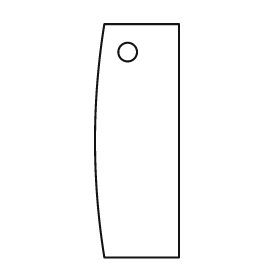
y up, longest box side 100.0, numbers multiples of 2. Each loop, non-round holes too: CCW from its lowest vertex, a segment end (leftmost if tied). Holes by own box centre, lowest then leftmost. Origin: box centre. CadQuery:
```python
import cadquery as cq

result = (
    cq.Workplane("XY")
    .moveTo(-14.0, -50.0)
    .lineTo(18.0, -50.0)
    .lineTo(18.0, 50.0)
    .lineTo(-14.0, 50.0)
    .threePointArc((-18.0, 0.0), (-14.0, -50.0))
    .close()
    .moveTo(-4.0, 38.0)
    .circle(4.0)
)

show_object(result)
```